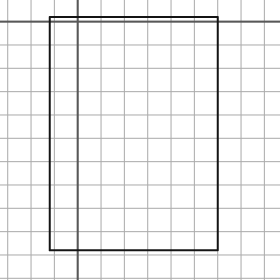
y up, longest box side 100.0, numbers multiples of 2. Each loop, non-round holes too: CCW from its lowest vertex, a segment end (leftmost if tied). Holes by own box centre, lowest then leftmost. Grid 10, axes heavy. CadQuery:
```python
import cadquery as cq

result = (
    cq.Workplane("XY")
    .moveTo(-12.0, -98.0)
    .lineTo(60.0, -98.0)
    .lineTo(60.0, 2.0)
    .lineTo(-12.0, 2.0)
    .close()
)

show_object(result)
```